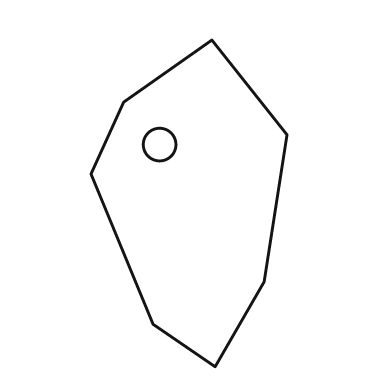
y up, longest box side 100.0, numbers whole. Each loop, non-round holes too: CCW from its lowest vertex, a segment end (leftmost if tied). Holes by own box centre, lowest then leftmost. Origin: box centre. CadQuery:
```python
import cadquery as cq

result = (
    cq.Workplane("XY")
    .moveTo(8.0, -50.0)
    .lineTo(23.0, -24.0)
    .lineTo(30.0, 21.0)
    .lineTo(7.0, 50.0)
    .lineTo(-20.0, 31.0)
    .lineTo(-30.0, 9.0)
    .lineTo(-11.0, -37.0)
    .close()
    .moveTo(-9.0, 18.0)
    .circle(5.0)
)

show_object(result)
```